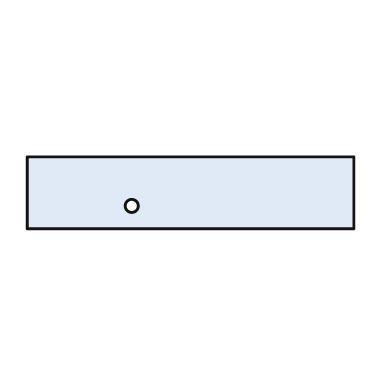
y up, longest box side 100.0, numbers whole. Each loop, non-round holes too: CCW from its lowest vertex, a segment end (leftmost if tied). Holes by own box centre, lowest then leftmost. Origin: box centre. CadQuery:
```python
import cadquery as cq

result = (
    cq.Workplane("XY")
    .moveTo(-50.0, -11.0)
    .lineTo(50.0, -11.0)
    .lineTo(50.0, 11.0)
    .lineTo(-50.0, 11.0)
    .close()
    .moveTo(-18.0, -4.0)
    .circle(2.0)
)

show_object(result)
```